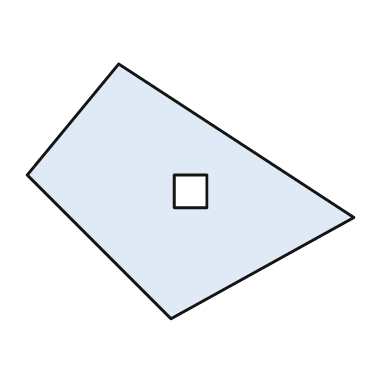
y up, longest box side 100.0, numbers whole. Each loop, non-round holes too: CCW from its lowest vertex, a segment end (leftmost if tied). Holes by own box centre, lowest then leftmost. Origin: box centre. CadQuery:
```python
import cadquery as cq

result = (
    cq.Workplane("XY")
    .moveTo(-6.0, -39.0)
    .lineTo(50.0, -8.0)
    .lineTo(-22.0, 39.0)
    .lineTo(-50.0, 5.0)
    .close()
    .moveTo(-5.0, -5.0)
    .lineTo(5.0, -5.0)
    .lineTo(5.0, 5.0)
    .lineTo(-5.0, 5.0)
    .close()
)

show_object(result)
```